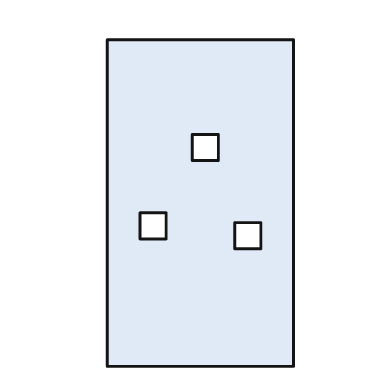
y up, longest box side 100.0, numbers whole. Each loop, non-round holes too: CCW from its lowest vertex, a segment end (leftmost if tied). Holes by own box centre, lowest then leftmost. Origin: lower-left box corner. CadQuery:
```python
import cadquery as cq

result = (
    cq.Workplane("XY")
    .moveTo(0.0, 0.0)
    .lineTo(57.0, 0.0)
    .lineTo(57.0, 100.0)
    .lineTo(0.0, 100.0)
    .close()
    .moveTo(39.0, 36.0)
    .lineTo(47.0, 36.0)
    .lineTo(47.0, 44.0)
    .lineTo(39.0, 44.0)
    .close()
    .moveTo(10.0, 39.0)
    .lineTo(18.0, 39.0)
    .lineTo(18.0, 47.0)
    .lineTo(10.0, 47.0)
    .close()
    .moveTo(26.0, 63.0)
    .lineTo(34.0, 63.0)
    .lineTo(34.0, 71.0)
    .lineTo(26.0, 71.0)
    .close()
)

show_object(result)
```